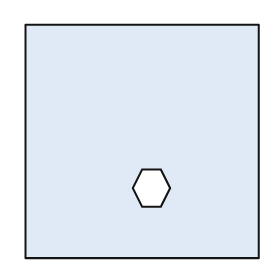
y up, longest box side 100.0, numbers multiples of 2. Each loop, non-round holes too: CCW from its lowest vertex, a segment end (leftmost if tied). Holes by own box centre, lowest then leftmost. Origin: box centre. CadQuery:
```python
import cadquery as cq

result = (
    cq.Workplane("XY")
    .moveTo(-50.0, -50.0)
    .lineTo(50.0, -50.0)
    .lineTo(50.0, 50.0)
    .lineTo(-50.0, 50.0)
    .close()
    .moveTo(0.0, -28.0)
    .lineTo(8.0, -28.0)
    .lineTo(12.0, -20.0)
    .lineTo(8.0, -12.0)
    .lineTo(0.0, -12.0)
    .lineTo(-4.0, -20.0)
    .close()
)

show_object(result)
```